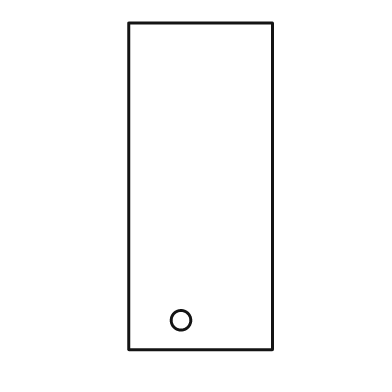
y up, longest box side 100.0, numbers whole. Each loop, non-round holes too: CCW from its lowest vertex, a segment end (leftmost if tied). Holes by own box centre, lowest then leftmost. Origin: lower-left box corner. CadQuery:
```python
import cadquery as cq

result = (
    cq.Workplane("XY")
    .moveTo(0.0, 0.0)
    .lineTo(44.0, 0.0)
    .lineTo(44.0, 100.0)
    .lineTo(0.0, 100.0)
    .close()
    .moveTo(16.0, 9.0)
    .circle(3.0)
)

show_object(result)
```